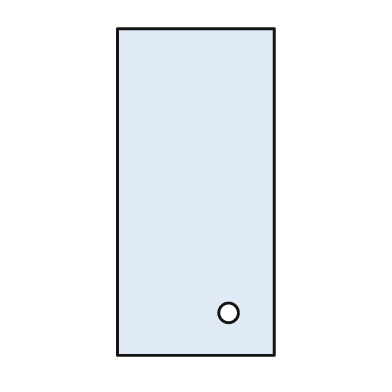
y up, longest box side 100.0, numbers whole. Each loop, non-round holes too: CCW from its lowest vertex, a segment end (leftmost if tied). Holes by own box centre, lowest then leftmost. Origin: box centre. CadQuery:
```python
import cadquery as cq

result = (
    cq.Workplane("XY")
    .moveTo(-24.0, -50.0)
    .lineTo(24.0, -50.0)
    .lineTo(24.0, 50.0)
    .lineTo(-24.0, 50.0)
    .close()
    .moveTo(10.0, -37.0)
    .circle(3.0)
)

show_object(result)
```